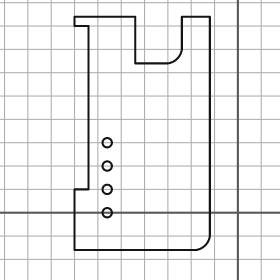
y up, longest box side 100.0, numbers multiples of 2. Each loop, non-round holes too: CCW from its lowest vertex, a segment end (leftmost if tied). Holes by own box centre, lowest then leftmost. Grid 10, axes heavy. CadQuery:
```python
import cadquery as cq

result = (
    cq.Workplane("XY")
    .moveTo(-70.0, -16.0)
    .lineTo(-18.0, -16.0)
    .threePointArc((-14.0, -14.0), (-12.0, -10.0))
    .lineTo(-12.0, 84.0)
    .lineTo(-24.0, 84.0)
    .lineTo(-24.0, 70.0)
    .threePointArc((-26.0, 66.0), (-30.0, 64.0))
    .lineTo(-44.0, 64.0)
    .lineTo(-44.0, 84.0)
    .lineTo(-70.0, 84.0)
    .lineTo(-70.0, 80.0)
    .lineTo(-64.0, 80.0)
    .lineTo(-64.0, 10.0)
    .lineTo(-70.0, 10.0)
    .close()
    .moveTo(-56.0, 0.0)
    .circle(2.0)
    .moveTo(-56.0, 10.0)
    .circle(2.0)
    .moveTo(-56.0, 20.0)
    .circle(2.0)
    .moveTo(-56.0, 30.0)
    .circle(2.0)
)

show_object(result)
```